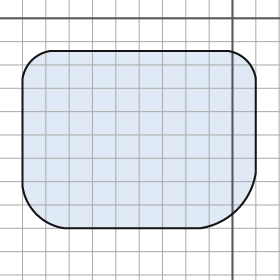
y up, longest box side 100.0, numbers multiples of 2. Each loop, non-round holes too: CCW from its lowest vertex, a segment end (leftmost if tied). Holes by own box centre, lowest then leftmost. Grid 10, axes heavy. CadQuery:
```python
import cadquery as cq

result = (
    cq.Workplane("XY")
    .moveTo(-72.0, -90.0)
    .lineTo(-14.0, -90.0)
    .threePointArc((2.0, -82.0), (10.0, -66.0))
    .lineTo(10.0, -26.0)
    .threePointArc((6.0, -18.0), (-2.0, -14.0))
    .lineTo(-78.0, -14.0)
    .threePointArc((-86.0, -18.0), (-90.0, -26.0))
    .lineTo(-90.0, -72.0)
    .threePointArc((-84.0, -84.0), (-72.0, -90.0))
    .close()
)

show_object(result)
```